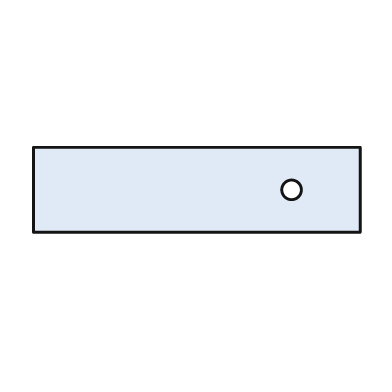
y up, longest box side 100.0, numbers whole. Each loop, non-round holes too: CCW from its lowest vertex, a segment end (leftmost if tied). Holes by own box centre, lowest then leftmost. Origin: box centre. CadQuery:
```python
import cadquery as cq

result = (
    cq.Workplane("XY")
    .moveTo(-50.0, -13.0)
    .lineTo(50.0, -13.0)
    .lineTo(50.0, 13.0)
    .lineTo(-50.0, 13.0)
    .close()
    .moveTo(29.0, 0.0)
    .circle(3.0)
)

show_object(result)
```